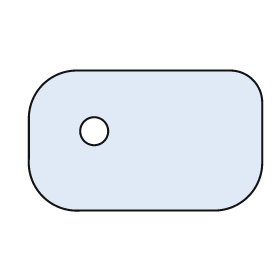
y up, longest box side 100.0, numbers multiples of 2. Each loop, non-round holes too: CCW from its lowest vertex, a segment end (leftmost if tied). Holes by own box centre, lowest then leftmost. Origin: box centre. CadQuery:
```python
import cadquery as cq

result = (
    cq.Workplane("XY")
    .moveTo(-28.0, -30.0)
    .lineTo(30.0, -30.0)
    .threePointArc((44.0, -24.0), (50.0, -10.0))
    .lineTo(50.0, 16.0)
    .threePointArc((46.0, 26.0), (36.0, 30.0))
    .lineTo(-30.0, 30.0)
    .threePointArc((-44.0, 24.0), (-50.0, 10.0))
    .lineTo(-50.0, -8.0)
    .threePointArc((-44.0, -24.0), (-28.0, -30.0))
    .close()
    .moveTo(-22.0, 4.0)
    .circle(6.0)
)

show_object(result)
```